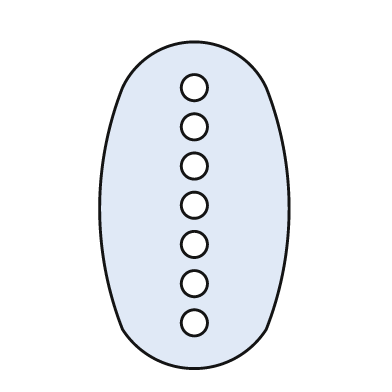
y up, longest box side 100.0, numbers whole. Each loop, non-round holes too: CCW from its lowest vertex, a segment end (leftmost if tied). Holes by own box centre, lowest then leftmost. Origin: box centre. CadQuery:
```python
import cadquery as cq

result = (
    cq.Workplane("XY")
    .moveTo(-22.0, -38.0)
    .threePointArc((0.0, -50.0), (22.0, -38.0))
    .threePointArc((29.0, -1.0), (22.0, 36.0))
    .threePointArc((0.0, 50.0), (-22.0, 36.0))
    .threePointArc((-29.0, -1.0), (-22.0, -38.0))
    .close()
    .moveTo(0.0, -36.0)
    .circle(4.0)
    .moveTo(0.0, -24.0)
    .circle(4.0)
    .moveTo(0.0, -12.0)
    .circle(4.0)
    .moveTo(0.0, 0.0)
    .circle(4.0)
    .moveTo(0.0, 12.0)
    .circle(4.0)
    .moveTo(0.0, 24.0)
    .circle(4.0)
    .moveTo(0.0, 36.0)
    .circle(4.0)
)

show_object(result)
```